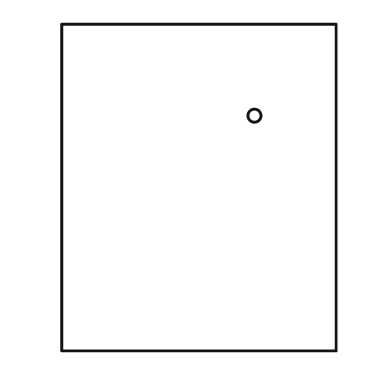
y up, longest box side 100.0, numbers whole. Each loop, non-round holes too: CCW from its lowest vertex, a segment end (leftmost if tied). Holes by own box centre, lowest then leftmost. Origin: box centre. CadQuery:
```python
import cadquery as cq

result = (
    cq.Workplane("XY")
    .moveTo(-42.0, -50.0)
    .lineTo(42.0, -50.0)
    .lineTo(42.0, 50.0)
    .lineTo(-42.0, 50.0)
    .close()
    .moveTo(17.0, 22.0)
    .circle(2.0)
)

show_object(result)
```